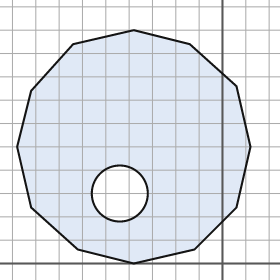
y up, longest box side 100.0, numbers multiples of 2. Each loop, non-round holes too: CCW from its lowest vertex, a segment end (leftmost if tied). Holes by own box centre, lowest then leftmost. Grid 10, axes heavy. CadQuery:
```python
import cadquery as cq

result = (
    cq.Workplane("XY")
    .moveTo(-38.0, 0.0)
    .lineTo(-12.0, 6.0)
    .lineTo(6.0, 24.0)
    .lineTo(12.0, 50.0)
    .lineTo(6.0, 76.0)
    .lineTo(-14.0, 94.0)
    .lineTo(-38.0, 100.0)
    .lineTo(-64.0, 94.0)
    .lineTo(-82.0, 74.0)
    .lineTo(-88.0, 50.0)
    .lineTo(-82.0, 24.0)
    .lineTo(-62.0, 6.0)
    .close()
    .moveTo(-44.0, 30.0)
    .circle(12.0)
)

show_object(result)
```